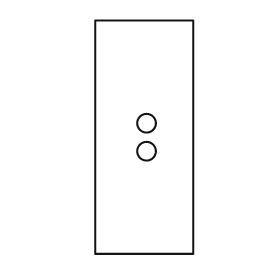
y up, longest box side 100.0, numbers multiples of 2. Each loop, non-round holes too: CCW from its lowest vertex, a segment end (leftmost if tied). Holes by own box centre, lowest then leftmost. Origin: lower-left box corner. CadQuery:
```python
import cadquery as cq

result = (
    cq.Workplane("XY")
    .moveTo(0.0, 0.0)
    .lineTo(42.0, 0.0)
    .lineTo(42.0, 100.0)
    .lineTo(0.0, 100.0)
    .close()
    .moveTo(22.0, 44.0)
    .circle(4.0)
    .moveTo(22.0, 56.0)
    .circle(4.0)
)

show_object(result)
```